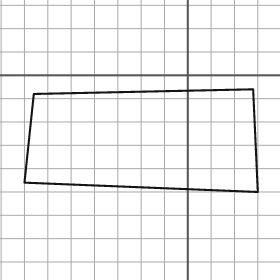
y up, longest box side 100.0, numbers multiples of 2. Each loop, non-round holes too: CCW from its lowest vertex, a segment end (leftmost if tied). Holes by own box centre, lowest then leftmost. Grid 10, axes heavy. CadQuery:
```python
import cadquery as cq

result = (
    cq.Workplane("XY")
    .moveTo(30.0, -50.0)
    .lineTo(28.0, -6.0)
    .lineTo(-66.0, -8.0)
    .lineTo(-70.0, -46.0)
    .close()
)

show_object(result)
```